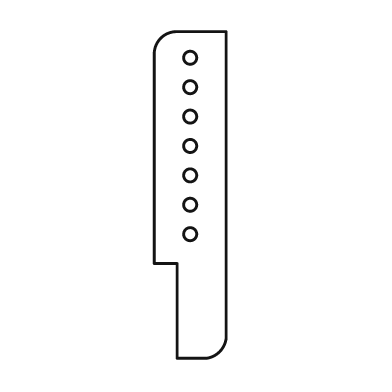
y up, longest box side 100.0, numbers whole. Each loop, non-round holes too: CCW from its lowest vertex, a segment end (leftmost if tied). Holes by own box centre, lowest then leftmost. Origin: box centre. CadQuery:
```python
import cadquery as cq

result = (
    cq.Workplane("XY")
    .moveTo(-4.0, -50.0)
    .lineTo(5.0, -50.0)
    .threePointArc((9.0, -48.0), (11.0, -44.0))
    .lineTo(11.0, 50.0)
    .lineTo(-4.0, 50.0)
    .threePointArc((-9.0, 48.0), (-11.0, 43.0))
    .lineTo(-11.0, -21.0)
    .lineTo(-4.0, -21.0)
    .close()
    .moveTo(0.0, -12.0)
    .circle(2.0)
    .moveTo(0.0, -3.0)
    .circle(2.0)
    .moveTo(0.0, 6.0)
    .circle(2.0)
    .moveTo(0.0, 15.0)
    .circle(2.0)
    .moveTo(0.0, 24.0)
    .circle(2.0)
    .moveTo(0.0, 33.0)
    .circle(2.0)
    .moveTo(0.0, 42.0)
    .circle(2.0)
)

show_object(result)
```